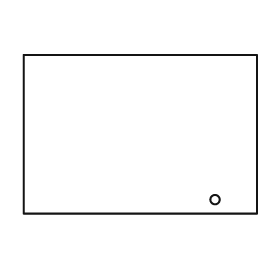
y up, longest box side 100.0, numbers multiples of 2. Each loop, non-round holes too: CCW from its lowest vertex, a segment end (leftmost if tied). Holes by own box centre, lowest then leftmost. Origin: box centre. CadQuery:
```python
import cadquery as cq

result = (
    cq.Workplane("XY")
    .moveTo(-50.0, -34.0)
    .lineTo(50.0, -34.0)
    .lineTo(50.0, 34.0)
    .lineTo(-50.0, 34.0)
    .close()
    .moveTo(32.0, -28.0)
    .circle(2.0)
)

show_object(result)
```